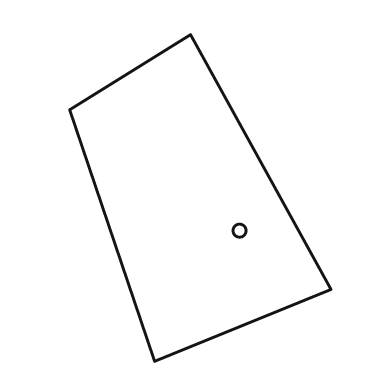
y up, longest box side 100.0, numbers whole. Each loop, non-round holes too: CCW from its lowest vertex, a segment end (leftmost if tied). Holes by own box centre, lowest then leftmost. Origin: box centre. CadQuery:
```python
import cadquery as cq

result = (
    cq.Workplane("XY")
    .moveTo(-14.0, -50.0)
    .lineTo(40.0, -28.0)
    .lineTo(-3.0, 50.0)
    .lineTo(-40.0, 27.0)
    .close()
    .moveTo(12.0, -10.0)
    .circle(2.0)
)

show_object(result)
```